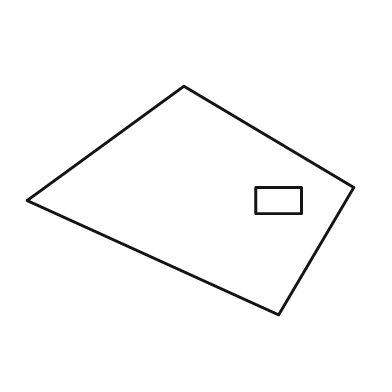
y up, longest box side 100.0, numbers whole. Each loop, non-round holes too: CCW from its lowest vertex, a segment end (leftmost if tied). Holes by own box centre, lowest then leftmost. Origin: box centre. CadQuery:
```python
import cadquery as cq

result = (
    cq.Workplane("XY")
    .moveTo(27.0, -35.0)
    .lineTo(50.0, 4.0)
    .lineTo(-2.0, 35.0)
    .lineTo(-50.0, 0.0)
    .close()
    .moveTo(20.0, -4.0)
    .lineTo(34.0, -4.0)
    .lineTo(34.0, 4.0)
    .lineTo(20.0, 4.0)
    .close()
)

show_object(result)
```